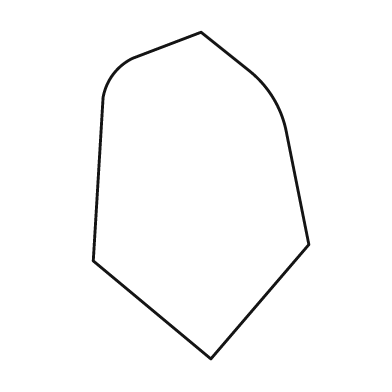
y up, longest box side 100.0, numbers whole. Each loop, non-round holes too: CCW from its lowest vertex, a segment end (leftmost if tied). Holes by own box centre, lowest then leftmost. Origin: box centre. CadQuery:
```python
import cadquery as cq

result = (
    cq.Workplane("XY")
    .moveTo(3.0, -50.0)
    .lineTo(33.0, -15.0)
    .lineTo(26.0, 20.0)
    .threePointArc((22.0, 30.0), (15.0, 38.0))
    .lineTo(0.0, 50.0)
    .lineTo(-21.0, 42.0)
    .threePointArc((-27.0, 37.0), (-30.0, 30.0))
    .lineTo(-33.0, -20.0)
    .close()
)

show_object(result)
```